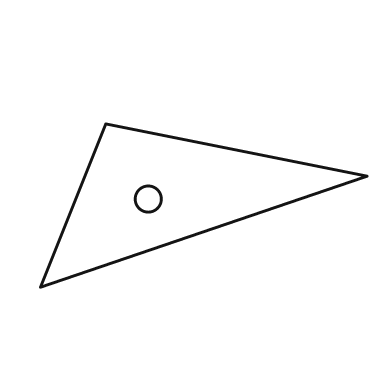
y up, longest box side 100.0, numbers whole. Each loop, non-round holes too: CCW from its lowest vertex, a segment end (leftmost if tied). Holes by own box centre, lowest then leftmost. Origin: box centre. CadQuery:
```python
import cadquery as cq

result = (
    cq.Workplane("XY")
    .moveTo(-50.0, -25.0)
    .lineTo(50.0, 9.0)
    .lineTo(-30.0, 25.0)
    .close()
    .moveTo(-17.0, 2.0)
    .circle(4.0)
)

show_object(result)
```